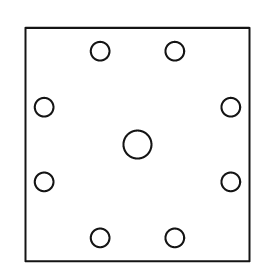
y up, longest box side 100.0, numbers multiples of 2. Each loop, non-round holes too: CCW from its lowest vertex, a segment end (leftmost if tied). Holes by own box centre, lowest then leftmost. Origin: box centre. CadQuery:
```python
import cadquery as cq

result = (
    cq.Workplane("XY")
    .moveTo(-48.0, -50.0)
    .lineTo(48.0, -50.0)
    .lineTo(48.0, 50.0)
    .lineTo(-48.0, 50.0)
    .close()
    .moveTo(-16.0, -40.0)
    .circle(4.0)
    .moveTo(16.0, -40.0)
    .circle(4.0)
    .moveTo(-40.0, -16.0)
    .circle(4.0)
    .moveTo(40.0, -16.0)
    .circle(4.0)
    .moveTo(0.0, 0.0)
    .circle(6.0)
    .moveTo(-40.0, 16.0)
    .circle(4.0)
    .moveTo(40.0, 16.0)
    .circle(4.0)
    .moveTo(-16.0, 40.0)
    .circle(4.0)
    .moveTo(16.0, 40.0)
    .circle(4.0)
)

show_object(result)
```